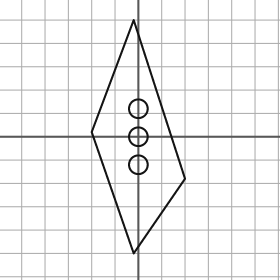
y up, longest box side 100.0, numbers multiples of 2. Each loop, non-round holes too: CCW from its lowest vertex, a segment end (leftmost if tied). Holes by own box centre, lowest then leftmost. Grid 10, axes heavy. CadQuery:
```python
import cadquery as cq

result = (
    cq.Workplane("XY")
    .moveTo(-2.0, -50.0)
    .lineTo(20.0, -18.0)
    .lineTo(-2.0, 50.0)
    .lineTo(-20.0, 2.0)
    .close()
    .moveTo(0.0, -12.0)
    .circle(4.0)
    .moveTo(0.0, 0.0)
    .circle(4.0)
    .moveTo(0.0, 12.0)
    .circle(4.0)
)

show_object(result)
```